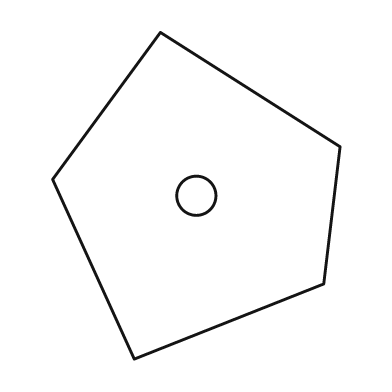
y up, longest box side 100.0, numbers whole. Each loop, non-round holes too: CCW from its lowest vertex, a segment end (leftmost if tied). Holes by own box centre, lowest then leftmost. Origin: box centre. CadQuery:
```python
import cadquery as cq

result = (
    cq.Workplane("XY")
    .moveTo(-19.0, -50.0)
    .lineTo(39.0, -27.0)
    .lineTo(44.0, 15.0)
    .lineTo(-11.0, 50.0)
    .lineTo(-44.0, 5.0)
    .close()
    .moveTo(0.0, 0.0)
    .circle(6.0)
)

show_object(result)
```